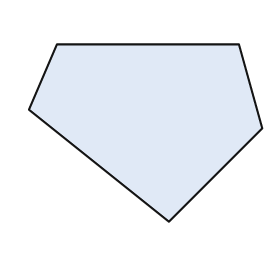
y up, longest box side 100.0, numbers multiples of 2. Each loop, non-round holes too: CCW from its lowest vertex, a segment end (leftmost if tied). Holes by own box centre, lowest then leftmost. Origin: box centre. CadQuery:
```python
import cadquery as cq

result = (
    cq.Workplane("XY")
    .moveTo(10.0, -38.0)
    .lineTo(50.0, 2.0)
    .lineTo(40.0, 38.0)
    .lineTo(-38.0, 38.0)
    .lineTo(-50.0, 10.0)
    .close()
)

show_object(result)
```